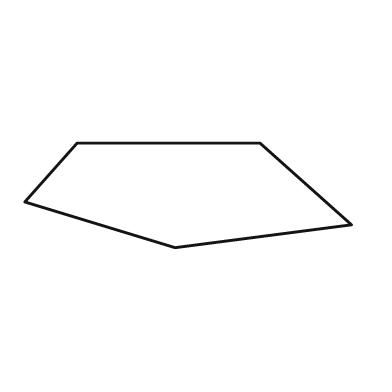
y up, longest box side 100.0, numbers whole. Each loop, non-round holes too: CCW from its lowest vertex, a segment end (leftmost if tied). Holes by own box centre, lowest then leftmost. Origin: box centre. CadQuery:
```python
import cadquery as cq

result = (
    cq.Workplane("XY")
    .moveTo(-4.0, -16.0)
    .lineTo(50.0, -9.0)
    .lineTo(22.0, 16.0)
    .lineTo(-34.0, 16.0)
    .lineTo(-50.0, -2.0)
    .close()
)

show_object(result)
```